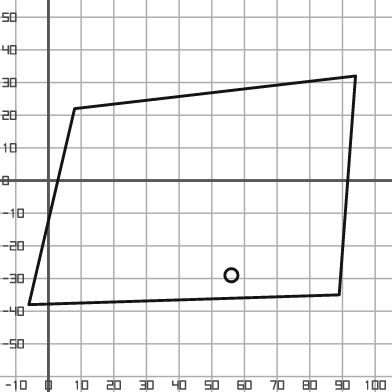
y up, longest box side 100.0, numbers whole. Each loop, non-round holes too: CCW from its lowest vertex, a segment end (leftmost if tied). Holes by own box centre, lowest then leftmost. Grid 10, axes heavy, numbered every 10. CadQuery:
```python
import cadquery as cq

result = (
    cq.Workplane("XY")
    .moveTo(-6.0, -38.0)
    .lineTo(89.0, -35.0)
    .lineTo(94.0, 32.0)
    .lineTo(8.0, 22.0)
    .close()
    .moveTo(56.0, -29.0)
    .circle(2.0)
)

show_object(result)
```